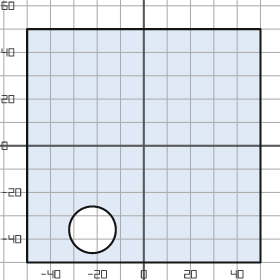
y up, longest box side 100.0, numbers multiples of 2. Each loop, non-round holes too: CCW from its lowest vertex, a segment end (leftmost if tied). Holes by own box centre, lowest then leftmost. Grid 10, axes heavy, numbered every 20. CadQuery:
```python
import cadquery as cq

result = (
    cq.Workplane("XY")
    .moveTo(-50.0, -50.0)
    .lineTo(50.0, -50.0)
    .lineTo(50.0, 50.0)
    .lineTo(-50.0, 50.0)
    .close()
    .moveTo(-22.0, -36.0)
    .circle(10.0)
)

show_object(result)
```